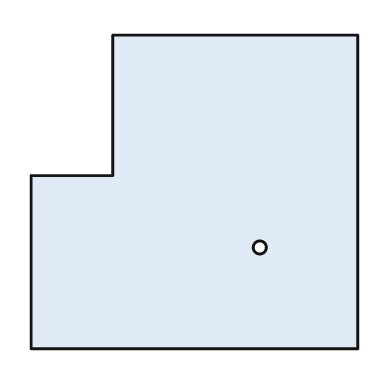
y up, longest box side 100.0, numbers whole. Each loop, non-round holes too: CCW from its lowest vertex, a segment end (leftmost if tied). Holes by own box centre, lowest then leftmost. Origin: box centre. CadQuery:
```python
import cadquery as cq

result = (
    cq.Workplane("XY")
    .moveTo(-50.0, -48.0)
    .lineTo(50.0, -48.0)
    .lineTo(50.0, 48.0)
    .lineTo(-25.0, 48.0)
    .lineTo(-25.0, 5.0)
    .lineTo(-50.0, 5.0)
    .close()
    .moveTo(20.0, -17.0)
    .circle(2.0)
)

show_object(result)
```